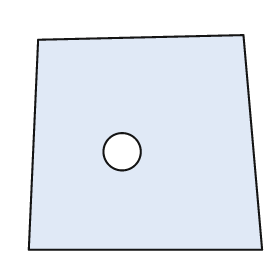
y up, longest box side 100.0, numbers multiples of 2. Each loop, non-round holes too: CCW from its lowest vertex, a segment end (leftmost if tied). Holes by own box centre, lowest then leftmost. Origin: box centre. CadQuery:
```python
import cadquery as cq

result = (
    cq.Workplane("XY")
    .moveTo(-50.0, -46.0)
    .lineTo(50.0, -46.0)
    .lineTo(42.0, 46.0)
    .lineTo(-46.0, 44.0)
    .close()
    .moveTo(-10.0, -4.0)
    .circle(8.0)
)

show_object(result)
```